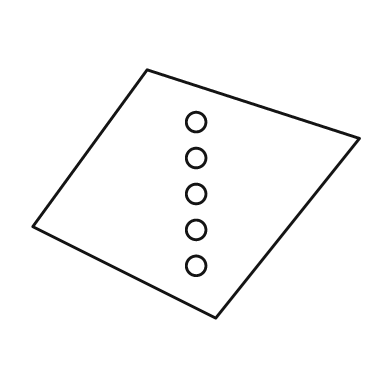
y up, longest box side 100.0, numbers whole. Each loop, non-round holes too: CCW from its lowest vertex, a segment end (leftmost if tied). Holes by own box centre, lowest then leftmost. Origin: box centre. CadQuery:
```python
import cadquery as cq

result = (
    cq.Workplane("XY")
    .moveTo(6.0, -38.0)
    .lineTo(50.0, 17.0)
    .lineTo(-15.0, 38.0)
    .lineTo(-50.0, -10.0)
    .close()
    .moveTo(0.0, -22.0)
    .circle(3.0)
    .moveTo(0.0, -11.0)
    .circle(3.0)
    .moveTo(0.0, 0.0)
    .circle(3.0)
    .moveTo(0.0, 11.0)
    .circle(3.0)
    .moveTo(0.0, 22.0)
    .circle(3.0)
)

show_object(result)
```